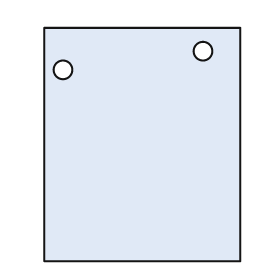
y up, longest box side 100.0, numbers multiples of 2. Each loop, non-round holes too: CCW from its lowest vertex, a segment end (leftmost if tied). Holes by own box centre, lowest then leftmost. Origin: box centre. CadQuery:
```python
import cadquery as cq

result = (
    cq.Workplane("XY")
    .moveTo(-42.0, -50.0)
    .lineTo(42.0, -50.0)
    .lineTo(42.0, 50.0)
    .lineTo(-42.0, 50.0)
    .close()
    .moveTo(-34.0, 32.0)
    .circle(4.0)
    .moveTo(26.0, 40.0)
    .circle(4.0)
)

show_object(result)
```